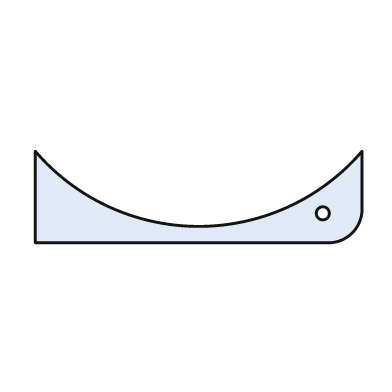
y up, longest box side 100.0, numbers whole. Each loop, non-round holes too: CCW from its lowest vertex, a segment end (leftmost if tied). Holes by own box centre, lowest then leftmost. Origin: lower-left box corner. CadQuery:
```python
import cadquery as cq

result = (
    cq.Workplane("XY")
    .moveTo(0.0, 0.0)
    .lineTo(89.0, 0.0)
    .threePointArc((97.0, 3.0), (100.0, 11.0))
    .lineTo(100.0, 28.0)
    .threePointArc((50.0, 5.0), (0.0, 28.0))
    .close()
    .moveTo(88.0, 9.0)
    .circle(2.0)
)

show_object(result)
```